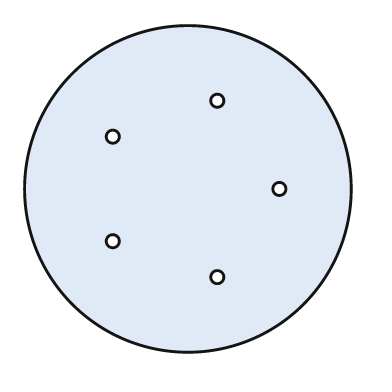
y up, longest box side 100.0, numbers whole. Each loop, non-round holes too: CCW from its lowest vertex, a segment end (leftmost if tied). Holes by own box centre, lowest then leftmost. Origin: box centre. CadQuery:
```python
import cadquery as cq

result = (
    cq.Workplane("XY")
    .moveTo(0.0, 0.0)
    .circle(50.0)
    .moveTo(9.0, -27.0)
    .circle(2.0)
    .moveTo(-23.0, -16.0)
    .circle(2.0)
    .moveTo(28.0, 0.0)
    .circle(2.0)
    .moveTo(-23.0, 16.0)
    .circle(2.0)
    .moveTo(9.0, 27.0)
    .circle(2.0)
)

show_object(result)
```